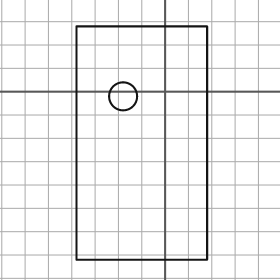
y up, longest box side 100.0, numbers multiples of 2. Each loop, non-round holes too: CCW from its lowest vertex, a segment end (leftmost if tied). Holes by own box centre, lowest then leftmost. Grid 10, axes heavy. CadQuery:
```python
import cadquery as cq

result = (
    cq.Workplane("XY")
    .moveTo(-38.0, -72.0)
    .lineTo(18.0, -72.0)
    .lineTo(18.0, 28.0)
    .lineTo(-38.0, 28.0)
    .close()
    .moveTo(-18.0, -2.0)
    .circle(6.0)
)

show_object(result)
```